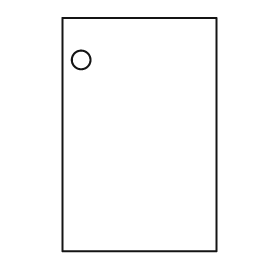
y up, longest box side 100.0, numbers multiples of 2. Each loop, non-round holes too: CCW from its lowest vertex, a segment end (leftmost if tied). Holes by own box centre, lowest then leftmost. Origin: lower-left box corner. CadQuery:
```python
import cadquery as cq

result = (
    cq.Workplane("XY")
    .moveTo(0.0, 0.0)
    .lineTo(66.0, 0.0)
    .lineTo(66.0, 100.0)
    .lineTo(0.0, 100.0)
    .close()
    .moveTo(8.0, 82.0)
    .circle(4.0)
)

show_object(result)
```